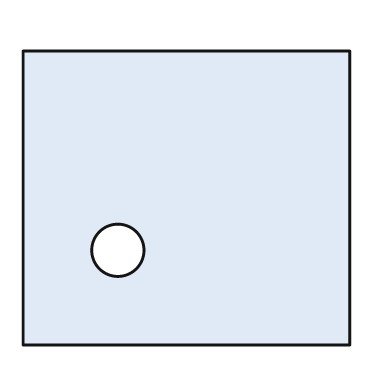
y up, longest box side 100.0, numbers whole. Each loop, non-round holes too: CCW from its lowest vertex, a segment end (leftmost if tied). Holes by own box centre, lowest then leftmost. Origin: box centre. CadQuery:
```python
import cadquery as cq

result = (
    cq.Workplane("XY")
    .moveTo(-50.0, -45.0)
    .lineTo(50.0, -45.0)
    .lineTo(50.0, 45.0)
    .lineTo(-50.0, 45.0)
    .close()
    .moveTo(-21.0, -16.0)
    .circle(8.0)
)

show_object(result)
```